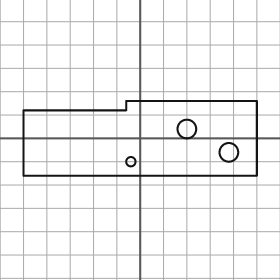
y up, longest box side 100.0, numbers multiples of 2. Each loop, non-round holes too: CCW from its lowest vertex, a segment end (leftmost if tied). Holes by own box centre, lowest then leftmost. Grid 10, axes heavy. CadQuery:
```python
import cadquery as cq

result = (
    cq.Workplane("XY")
    .moveTo(-50.0, -16.0)
    .lineTo(50.0, -16.0)
    .lineTo(50.0, 16.0)
    .lineTo(-6.0, 16.0)
    .lineTo(-6.0, 12.0)
    .lineTo(-50.0, 12.0)
    .close()
    .moveTo(-4.0, -10.0)
    .circle(2.0)
    .moveTo(38.0, -6.0)
    .circle(4.0)
    .moveTo(20.0, 4.0)
    .circle(4.0)
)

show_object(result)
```